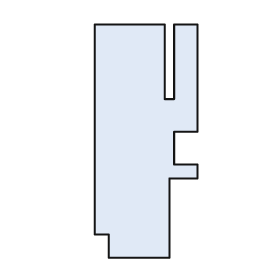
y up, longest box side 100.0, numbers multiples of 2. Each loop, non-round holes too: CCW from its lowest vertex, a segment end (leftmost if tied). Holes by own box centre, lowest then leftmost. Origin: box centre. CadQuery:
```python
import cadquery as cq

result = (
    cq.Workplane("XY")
    .moveTo(-16.0, -50.0)
    .lineTo(10.0, -50.0)
    .lineTo(10.0, -16.0)
    .lineTo(22.0, -16.0)
    .lineTo(22.0, -10.0)
    .lineTo(12.0, -10.0)
    .lineTo(12.0, 4.0)
    .lineTo(22.0, 4.0)
    .lineTo(22.0, 50.0)
    .lineTo(12.0, 50.0)
    .lineTo(12.0, 18.0)
    .lineTo(8.0, 18.0)
    .lineTo(8.0, 50.0)
    .lineTo(-22.0, 50.0)
    .lineTo(-22.0, -40.0)
    .lineTo(-16.0, -40.0)
    .close()
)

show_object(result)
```